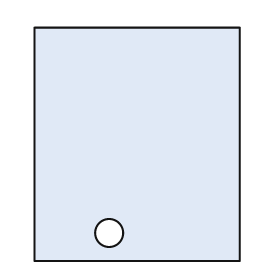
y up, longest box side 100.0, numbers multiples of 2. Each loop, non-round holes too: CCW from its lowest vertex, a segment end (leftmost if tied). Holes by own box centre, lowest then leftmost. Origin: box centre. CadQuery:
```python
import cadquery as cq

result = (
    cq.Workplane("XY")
    .moveTo(-44.0, -50.0)
    .lineTo(44.0, -50.0)
    .lineTo(44.0, 50.0)
    .lineTo(-44.0, 50.0)
    .close()
    .moveTo(-12.0, -38.0)
    .circle(6.0)
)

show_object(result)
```